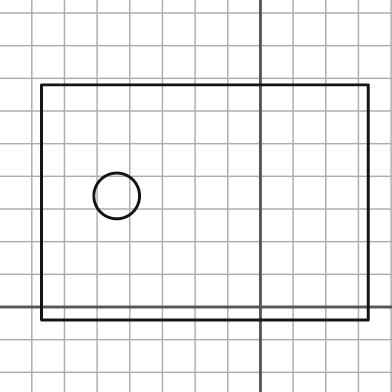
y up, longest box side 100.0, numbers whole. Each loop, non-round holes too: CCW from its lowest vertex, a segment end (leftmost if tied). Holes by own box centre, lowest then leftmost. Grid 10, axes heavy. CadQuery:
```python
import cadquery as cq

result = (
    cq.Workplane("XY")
    .moveTo(-67.0, -4.0)
    .lineTo(33.0, -4.0)
    .lineTo(33.0, 68.0)
    .lineTo(-67.0, 68.0)
    .close()
    .moveTo(-44.0, 34.0)
    .circle(7.0)
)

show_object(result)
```